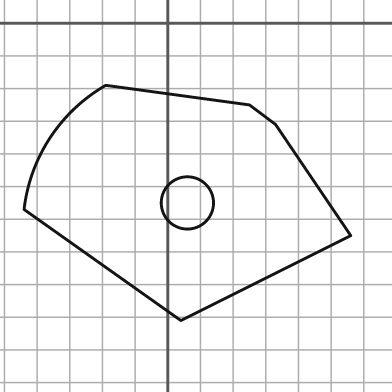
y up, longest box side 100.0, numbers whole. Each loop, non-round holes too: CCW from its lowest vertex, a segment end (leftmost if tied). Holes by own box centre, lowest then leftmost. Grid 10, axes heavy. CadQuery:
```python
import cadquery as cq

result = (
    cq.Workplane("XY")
    .moveTo(4.0, -91.0)
    .lineTo(56.0, -65.0)
    .lineTo(33.0, -31.0)
    .lineTo(25.0, -25.0)
    .lineTo(-19.0, -19.0)
    .threePointArc((-36.0, -35.0), (-44.0, -57.0))
    .close()
    .moveTo(6.0, -55.0)
    .circle(8.0)
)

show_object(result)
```